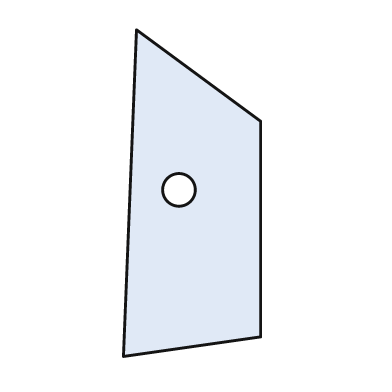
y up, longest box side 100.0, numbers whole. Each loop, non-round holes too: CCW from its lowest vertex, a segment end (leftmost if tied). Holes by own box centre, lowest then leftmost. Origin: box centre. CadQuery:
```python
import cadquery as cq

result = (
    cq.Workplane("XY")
    .moveTo(-21.0, -50.0)
    .lineTo(21.0, -44.0)
    .lineTo(21.0, 22.0)
    .lineTo(-17.0, 50.0)
    .close()
    .moveTo(-4.0, 1.0)
    .circle(5.0)
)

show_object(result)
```